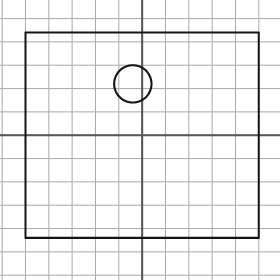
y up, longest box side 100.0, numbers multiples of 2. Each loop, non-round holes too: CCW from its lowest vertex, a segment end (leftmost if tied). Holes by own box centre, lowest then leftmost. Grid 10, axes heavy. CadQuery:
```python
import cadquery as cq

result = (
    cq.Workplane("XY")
    .moveTo(-50.0, -44.0)
    .lineTo(50.0, -44.0)
    .lineTo(50.0, 44.0)
    .lineTo(-50.0, 44.0)
    .close()
    .moveTo(-4.0, 22.0)
    .circle(8.0)
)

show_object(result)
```